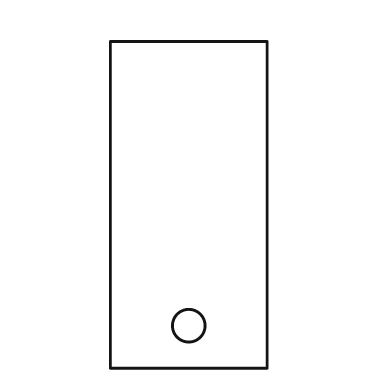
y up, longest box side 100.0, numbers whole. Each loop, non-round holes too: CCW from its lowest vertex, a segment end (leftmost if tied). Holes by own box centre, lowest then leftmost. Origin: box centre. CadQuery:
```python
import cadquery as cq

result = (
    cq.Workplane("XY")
    .moveTo(-24.0, -50.0)
    .lineTo(24.0, -50.0)
    .lineTo(24.0, 50.0)
    .lineTo(-24.0, 50.0)
    .close()
    .moveTo(0.0, -37.0)
    .circle(5.0)
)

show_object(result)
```